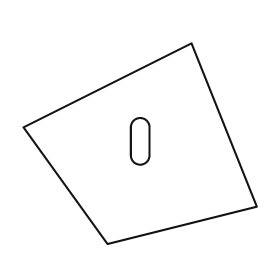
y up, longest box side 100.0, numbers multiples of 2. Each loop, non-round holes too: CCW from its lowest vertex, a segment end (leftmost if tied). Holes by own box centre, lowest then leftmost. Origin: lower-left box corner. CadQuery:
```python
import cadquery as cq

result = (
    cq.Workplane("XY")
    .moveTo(36.0, 0.0)
    .lineTo(100.0, 16.0)
    .lineTo(72.0, 86.0)
    .lineTo(0.0, 50.0)
    .close()
    .moveTo(46.0, 38.0)
    .threePointArc((50.0, 34.0), (54.0, 38.0))
    .lineTo(54.0, 50.0)
    .threePointArc((50.0, 54.0), (46.0, 50.0))
    .close()
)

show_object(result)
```